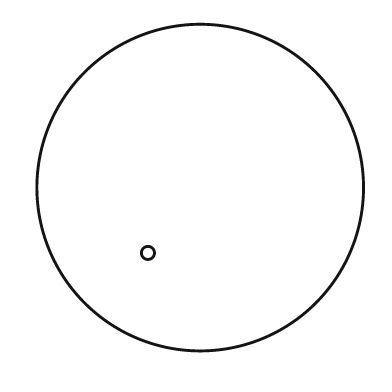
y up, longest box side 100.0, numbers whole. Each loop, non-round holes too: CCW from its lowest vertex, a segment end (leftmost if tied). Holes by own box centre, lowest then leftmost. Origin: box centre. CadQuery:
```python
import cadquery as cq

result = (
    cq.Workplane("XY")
    .moveTo(0.0, 0.0)
    .circle(50.0)
    .moveTo(-16.0, -20.0)
    .circle(2.0)
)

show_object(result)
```